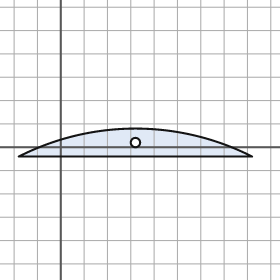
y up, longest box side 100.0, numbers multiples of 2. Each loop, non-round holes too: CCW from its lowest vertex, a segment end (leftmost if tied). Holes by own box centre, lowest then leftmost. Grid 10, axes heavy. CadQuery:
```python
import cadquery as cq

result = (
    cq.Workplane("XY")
    .moveTo(-18.0, -4.0)
    .lineTo(82.0, -4.0)
    .threePointArc((32.0, 8.0), (-18.0, -4.0))
    .close()
    .moveTo(32.0, 2.0)
    .circle(2.0)
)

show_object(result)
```